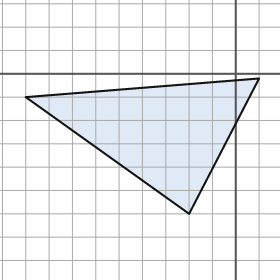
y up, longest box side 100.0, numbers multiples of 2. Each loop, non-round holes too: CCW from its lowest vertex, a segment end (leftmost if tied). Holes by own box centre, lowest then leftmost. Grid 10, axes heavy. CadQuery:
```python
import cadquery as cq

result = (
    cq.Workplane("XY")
    .moveTo(-20.0, -60.0)
    .lineTo(10.0, -2.0)
    .lineTo(-90.0, -10.0)
    .close()
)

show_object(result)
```